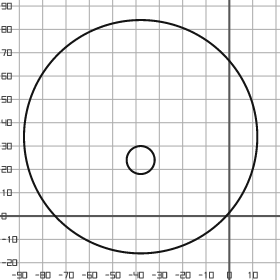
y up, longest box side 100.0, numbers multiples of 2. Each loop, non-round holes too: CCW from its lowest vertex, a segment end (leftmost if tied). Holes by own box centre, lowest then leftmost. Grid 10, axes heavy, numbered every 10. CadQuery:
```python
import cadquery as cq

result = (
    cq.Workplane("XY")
    .moveTo(-38.0, 34.0)
    .circle(50.0)
    .moveTo(-38.0, 24.0)
    .circle(6.0)
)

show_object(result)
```